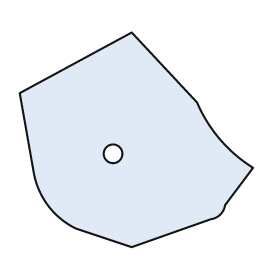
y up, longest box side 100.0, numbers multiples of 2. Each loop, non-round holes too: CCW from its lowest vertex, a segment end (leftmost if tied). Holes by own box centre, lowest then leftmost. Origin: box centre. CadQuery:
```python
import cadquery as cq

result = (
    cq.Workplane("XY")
    .moveTo(-2.0, -46.0)
    .lineTo(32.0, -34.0)
    .threePointArc((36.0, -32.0), (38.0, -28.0))
    .lineTo(50.0, -12.0)
    .threePointArc((36.0, 0.0), (26.0, 16.0))
    .lineTo(-2.0, 46.0)
    .lineTo(-50.0, 20.0)
    .lineTo(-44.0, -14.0)
    .threePointArc((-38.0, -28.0), (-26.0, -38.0))
    .close()
    .moveTo(-10.0, -6.0)
    .circle(4.0)
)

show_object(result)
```